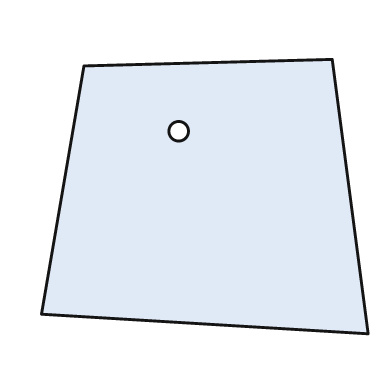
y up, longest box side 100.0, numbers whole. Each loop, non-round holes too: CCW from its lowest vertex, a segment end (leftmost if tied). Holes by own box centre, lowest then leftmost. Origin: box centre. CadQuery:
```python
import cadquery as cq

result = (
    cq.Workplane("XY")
    .moveTo(50.0, -42.0)
    .lineTo(39.0, 42.0)
    .lineTo(-37.0, 40.0)
    .lineTo(-50.0, -36.0)
    .close()
    .moveTo(-8.0, 20.0)
    .circle(3.0)
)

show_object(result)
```